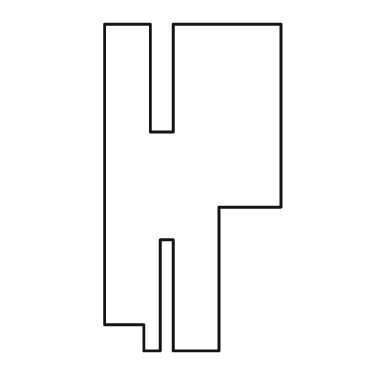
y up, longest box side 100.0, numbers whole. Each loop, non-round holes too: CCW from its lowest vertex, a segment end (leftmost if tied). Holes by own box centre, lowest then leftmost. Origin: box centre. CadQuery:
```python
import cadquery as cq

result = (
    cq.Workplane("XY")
    .moveTo(-15.0, -50.0)
    .lineTo(-10.0, -50.0)
    .lineTo(-10.0, -16.0)
    .lineTo(-6.0, -16.0)
    .lineTo(-6.0, -50.0)
    .lineTo(8.0, -50.0)
    .lineTo(8.0, -6.0)
    .lineTo(27.0, -6.0)
    .lineTo(27.0, 50.0)
    .lineTo(-6.0, 50.0)
    .lineTo(-6.0, 17.0)
    .lineTo(-13.0, 17.0)
    .lineTo(-13.0, 50.0)
    .lineTo(-27.0, 50.0)
    .lineTo(-27.0, -42.0)
    .lineTo(-15.0, -42.0)
    .close()
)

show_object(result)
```